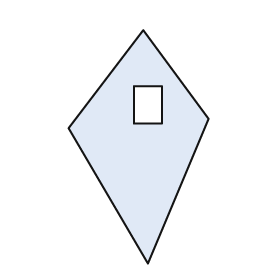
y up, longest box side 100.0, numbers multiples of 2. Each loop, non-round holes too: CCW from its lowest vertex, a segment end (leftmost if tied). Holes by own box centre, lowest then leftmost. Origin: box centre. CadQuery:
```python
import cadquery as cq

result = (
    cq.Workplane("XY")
    .moveTo(4.0, -50.0)
    .lineTo(30.0, 12.0)
    .lineTo(2.0, 50.0)
    .lineTo(-30.0, 8.0)
    .close()
    .moveTo(-2.0, 10.0)
    .lineTo(10.0, 10.0)
    .lineTo(10.0, 26.0)
    .lineTo(-2.0, 26.0)
    .close()
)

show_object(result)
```